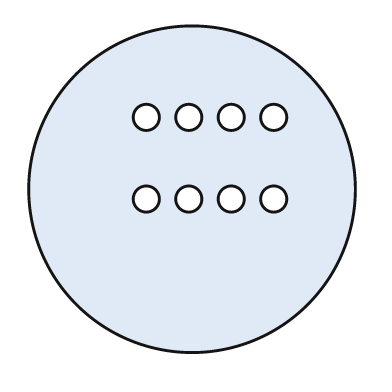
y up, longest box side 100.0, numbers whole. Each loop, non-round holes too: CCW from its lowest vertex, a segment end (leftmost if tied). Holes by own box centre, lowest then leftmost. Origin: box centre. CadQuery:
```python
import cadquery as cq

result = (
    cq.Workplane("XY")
    .moveTo(0.0, 0.0)
    .circle(50.0)
    .moveTo(-14.0, -3.0)
    .circle(4.0)
    .moveTo(-1.0, -3.0)
    .circle(4.0)
    .moveTo(12.0, -3.0)
    .circle(4.0)
    .moveTo(25.0, -3.0)
    .circle(4.0)
    .moveTo(-14.0, 22.0)
    .circle(4.0)
    .moveTo(-1.0, 22.0)
    .circle(4.0)
    .moveTo(12.0, 22.0)
    .circle(4.0)
    .moveTo(25.0, 22.0)
    .circle(4.0)
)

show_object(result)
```